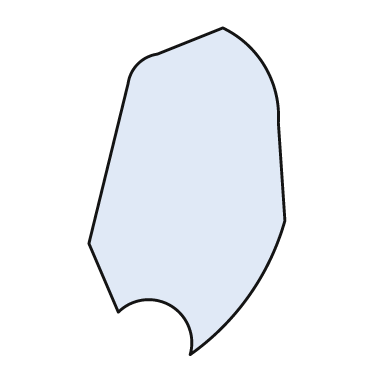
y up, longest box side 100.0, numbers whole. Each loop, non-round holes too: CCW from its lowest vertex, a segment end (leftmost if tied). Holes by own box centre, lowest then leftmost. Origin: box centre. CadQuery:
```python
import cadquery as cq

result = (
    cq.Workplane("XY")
    .moveTo(1.0, -50.0)
    .threePointArc((19.0, -32.0), (30.0, -9.0))
    .lineTo(28.0, 21.0)
    .threePointArc((24.0, 38.0), (11.0, 50.0))
    .lineTo(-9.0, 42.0)
    .threePointArc((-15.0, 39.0), (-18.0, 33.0))
    .lineTo(-30.0, -16.0)
    .lineTo(-21.0, -37.0)
    .threePointArc((-5.0, -35.0), (1.0, -50.0))
    .close()
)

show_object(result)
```